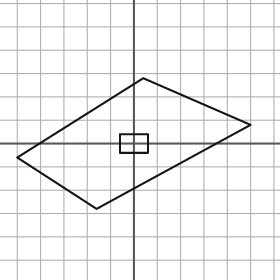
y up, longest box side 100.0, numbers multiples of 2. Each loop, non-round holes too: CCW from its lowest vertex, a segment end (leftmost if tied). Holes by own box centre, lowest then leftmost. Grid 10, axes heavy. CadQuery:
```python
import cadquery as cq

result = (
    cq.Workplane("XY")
    .moveTo(-16.0, -28.0)
    .lineTo(50.0, 8.0)
    .lineTo(4.0, 28.0)
    .lineTo(-50.0, -6.0)
    .close()
    .moveTo(-6.0, -4.0)
    .lineTo(6.0, -4.0)
    .lineTo(6.0, 4.0)
    .lineTo(-6.0, 4.0)
    .close()
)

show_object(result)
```